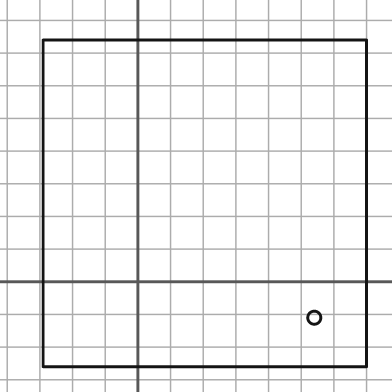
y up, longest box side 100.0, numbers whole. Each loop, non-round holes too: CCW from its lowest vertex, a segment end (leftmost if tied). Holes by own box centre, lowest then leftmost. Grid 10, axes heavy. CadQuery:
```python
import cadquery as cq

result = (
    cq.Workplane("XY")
    .moveTo(-29.0, -26.0)
    .lineTo(70.0, -26.0)
    .lineTo(70.0, 74.0)
    .lineTo(-29.0, 74.0)
    .close()
    .moveTo(54.0, -11.0)
    .circle(2.0)
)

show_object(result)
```